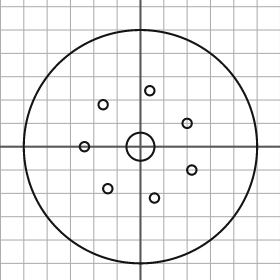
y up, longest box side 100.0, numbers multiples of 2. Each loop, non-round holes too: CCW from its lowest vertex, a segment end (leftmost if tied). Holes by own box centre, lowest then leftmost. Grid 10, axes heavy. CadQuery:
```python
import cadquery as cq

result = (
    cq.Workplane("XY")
    .moveTo(0.0, 0.0)
    .circle(50.0)
    .moveTo(6.0, -22.0)
    .circle(2.0)
    .moveTo(-14.0, -18.0)
    .circle(2.0)
    .moveTo(22.0, -10.0)
    .circle(2.0)
    .moveTo(-24.0, 0.0)
    .circle(2.0)
    .moveTo(0.0, 0.0)
    .circle(6.0)
    .moveTo(20.0, 10.0)
    .circle(2.0)
    .moveTo(-16.0, 18.0)
    .circle(2.0)
    .moveTo(4.0, 24.0)
    .circle(2.0)
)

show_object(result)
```